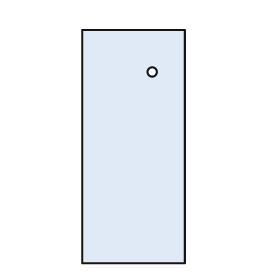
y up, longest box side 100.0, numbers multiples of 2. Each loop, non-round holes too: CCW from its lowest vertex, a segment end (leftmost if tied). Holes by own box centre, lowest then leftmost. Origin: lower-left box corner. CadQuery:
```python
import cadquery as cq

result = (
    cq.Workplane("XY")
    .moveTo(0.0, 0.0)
    .lineTo(44.0, 0.0)
    .lineTo(44.0, 100.0)
    .lineTo(0.0, 100.0)
    .close()
    .moveTo(30.0, 82.0)
    .circle(2.0)
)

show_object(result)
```